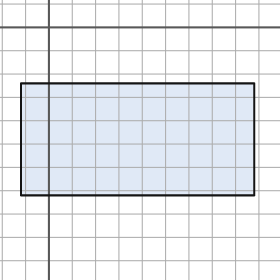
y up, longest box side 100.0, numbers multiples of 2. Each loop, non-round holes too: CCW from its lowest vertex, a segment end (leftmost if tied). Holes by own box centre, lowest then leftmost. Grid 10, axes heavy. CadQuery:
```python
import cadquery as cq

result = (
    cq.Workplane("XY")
    .moveTo(-12.0, -72.0)
    .lineTo(88.0, -72.0)
    .lineTo(88.0, -24.0)
    .lineTo(-12.0, -24.0)
    .close()
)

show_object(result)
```